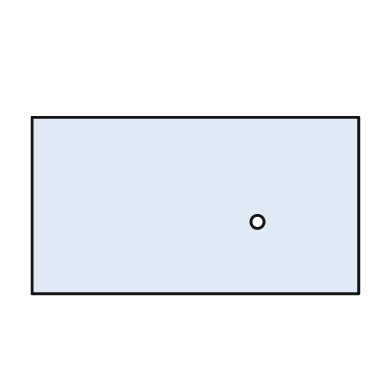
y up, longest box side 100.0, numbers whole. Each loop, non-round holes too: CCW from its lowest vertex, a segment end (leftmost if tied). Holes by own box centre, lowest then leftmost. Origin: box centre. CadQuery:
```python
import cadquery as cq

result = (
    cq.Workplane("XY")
    .moveTo(-50.0, -27.0)
    .lineTo(50.0, -27.0)
    .lineTo(50.0, 27.0)
    .lineTo(-50.0, 27.0)
    .close()
    .moveTo(19.0, -5.0)
    .circle(2.0)
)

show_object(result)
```